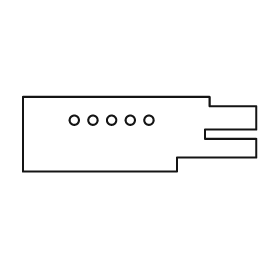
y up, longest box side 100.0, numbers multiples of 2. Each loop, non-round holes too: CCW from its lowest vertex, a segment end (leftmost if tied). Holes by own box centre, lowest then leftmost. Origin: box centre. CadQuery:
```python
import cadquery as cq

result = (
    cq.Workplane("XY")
    .moveTo(-50.0, -16.0)
    .lineTo(16.0, -16.0)
    .lineTo(16.0, -10.0)
    .lineTo(50.0, -10.0)
    .lineTo(50.0, -2.0)
    .lineTo(28.0, -2.0)
    .lineTo(28.0, 2.0)
    .lineTo(50.0, 2.0)
    .lineTo(50.0, 12.0)
    .lineTo(30.0, 12.0)
    .lineTo(30.0, 16.0)
    .lineTo(-50.0, 16.0)
    .close()
    .moveTo(-28.0, 6.0)
    .circle(2.0)
    .moveTo(-20.0, 6.0)
    .circle(2.0)
    .moveTo(-12.0, 6.0)
    .circle(2.0)
    .moveTo(-4.0, 6.0)
    .circle(2.0)
    .moveTo(4.0, 6.0)
    .circle(2.0)
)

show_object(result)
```